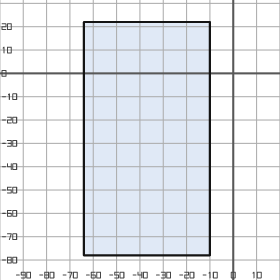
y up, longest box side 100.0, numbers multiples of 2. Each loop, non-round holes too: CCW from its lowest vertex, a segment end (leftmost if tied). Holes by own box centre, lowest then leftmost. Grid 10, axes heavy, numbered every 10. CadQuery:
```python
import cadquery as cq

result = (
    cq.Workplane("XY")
    .moveTo(-64.0, -78.0)
    .lineTo(-10.0, -78.0)
    .lineTo(-10.0, 22.0)
    .lineTo(-64.0, 22.0)
    .close()
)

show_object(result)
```